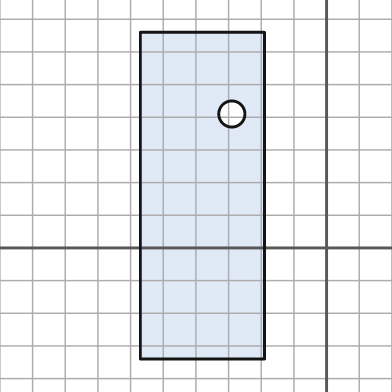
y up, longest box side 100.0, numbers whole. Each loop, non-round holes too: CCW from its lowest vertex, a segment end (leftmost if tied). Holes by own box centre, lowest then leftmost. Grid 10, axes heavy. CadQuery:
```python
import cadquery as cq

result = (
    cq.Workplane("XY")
    .moveTo(-57.0, -34.0)
    .lineTo(-19.0, -34.0)
    .lineTo(-19.0, 66.0)
    .lineTo(-57.0, 66.0)
    .close()
    .moveTo(-29.0, 41.0)
    .circle(4.0)
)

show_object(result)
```